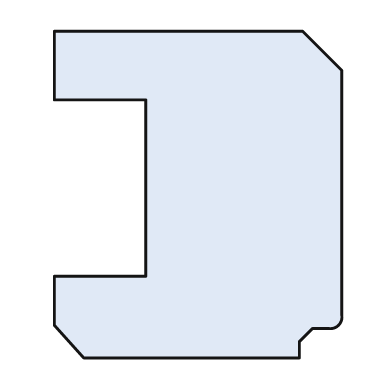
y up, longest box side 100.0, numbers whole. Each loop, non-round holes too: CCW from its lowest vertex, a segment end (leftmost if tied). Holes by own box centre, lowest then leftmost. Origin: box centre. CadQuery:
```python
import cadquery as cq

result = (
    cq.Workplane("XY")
    .moveTo(-35.0, -50.0)
    .lineTo(31.0, -50.0)
    .lineTo(31.0, -45.0)
    .lineTo(35.0, -41.0)
    .lineTo(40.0, -41.0)
    .threePointArc((43.0, -40.0), (44.0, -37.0))
    .lineTo(44.0, 38.0)
    .lineTo(32.0, 50.0)
    .lineTo(-44.0, 50.0)
    .lineTo(-44.0, 29.0)
    .lineTo(-16.0, 29.0)
    .lineTo(-16.0, -25.0)
    .lineTo(-44.0, -25.0)
    .lineTo(-44.0, -40.0)
    .close()
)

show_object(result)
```